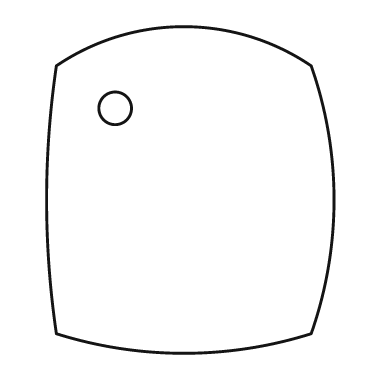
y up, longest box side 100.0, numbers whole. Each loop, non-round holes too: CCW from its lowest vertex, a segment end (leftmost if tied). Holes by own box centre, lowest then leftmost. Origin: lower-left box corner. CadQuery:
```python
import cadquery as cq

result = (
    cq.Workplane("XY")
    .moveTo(3.0, 6.0)
    .threePointArc((42.0, 0.0), (81.0, 6.0))
    .threePointArc((88.0, 47.0), (81.0, 88.0))
    .threePointArc((42.0, 100.0), (3.0, 88.0))
    .threePointArc((0.0, 47.0), (3.0, 6.0))
    .close()
    .moveTo(21.0, 75.0)
    .circle(5.0)
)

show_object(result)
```